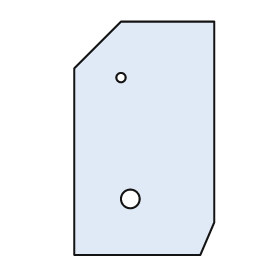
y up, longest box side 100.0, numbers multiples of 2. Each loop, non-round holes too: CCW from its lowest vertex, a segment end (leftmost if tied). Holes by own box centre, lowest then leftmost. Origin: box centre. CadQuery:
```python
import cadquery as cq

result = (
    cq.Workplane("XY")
    .moveTo(-30.0, -50.0)
    .lineTo(24.0, -50.0)
    .lineTo(30.0, -36.0)
    .lineTo(30.0, 50.0)
    .lineTo(-10.0, 50.0)
    .lineTo(-30.0, 30.0)
    .close()
    .moveTo(-6.0, -26.0)
    .circle(4.0)
    .moveTo(-10.0, 26.0)
    .circle(2.0)
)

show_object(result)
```